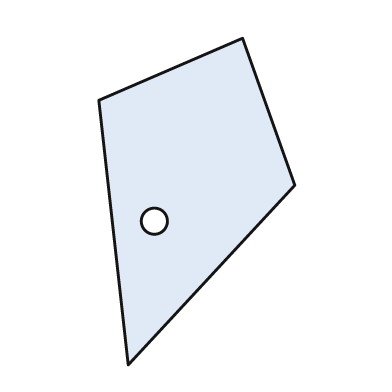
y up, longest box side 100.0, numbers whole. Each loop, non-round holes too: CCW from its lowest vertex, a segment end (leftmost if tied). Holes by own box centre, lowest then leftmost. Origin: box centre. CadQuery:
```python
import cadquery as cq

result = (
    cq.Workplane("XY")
    .moveTo(-21.0, -50.0)
    .lineTo(30.0, 5.0)
    .lineTo(14.0, 50.0)
    .lineTo(-30.0, 31.0)
    .close()
    .moveTo(-13.0, -6.0)
    .circle(4.0)
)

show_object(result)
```